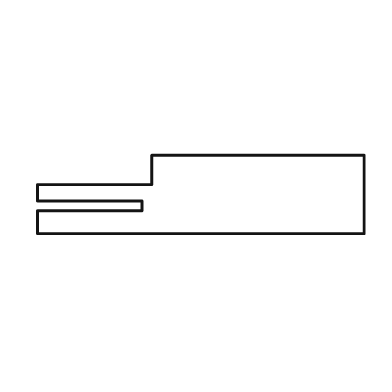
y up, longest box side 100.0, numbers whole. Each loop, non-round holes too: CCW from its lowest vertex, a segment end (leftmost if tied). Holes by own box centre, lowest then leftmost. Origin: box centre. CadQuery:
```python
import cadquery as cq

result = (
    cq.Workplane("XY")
    .moveTo(-50.0, -12.0)
    .lineTo(50.0, -12.0)
    .lineTo(50.0, 12.0)
    .lineTo(-15.0, 12.0)
    .lineTo(-15.0, 3.0)
    .lineTo(-50.0, 3.0)
    .lineTo(-50.0, -2.0)
    .lineTo(-18.0, -2.0)
    .lineTo(-18.0, -5.0)
    .lineTo(-50.0, -5.0)
    .close()
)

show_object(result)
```